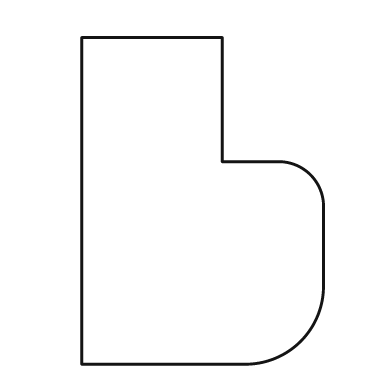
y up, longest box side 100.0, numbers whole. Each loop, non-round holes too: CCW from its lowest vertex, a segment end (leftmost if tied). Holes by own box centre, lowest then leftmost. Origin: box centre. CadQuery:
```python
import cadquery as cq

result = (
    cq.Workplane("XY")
    .moveTo(-37.0, -50.0)
    .lineTo(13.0, -50.0)
    .threePointArc((30.0, -43.0), (37.0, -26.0))
    .lineTo(37.0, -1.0)
    .threePointArc((33.0, 8.0), (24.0, 12.0))
    .lineTo(6.0, 12.0)
    .lineTo(6.0, 50.0)
    .lineTo(-37.0, 50.0)
    .close()
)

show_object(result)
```